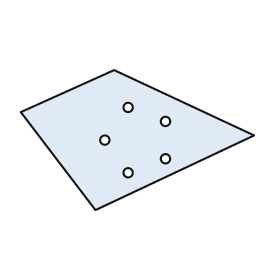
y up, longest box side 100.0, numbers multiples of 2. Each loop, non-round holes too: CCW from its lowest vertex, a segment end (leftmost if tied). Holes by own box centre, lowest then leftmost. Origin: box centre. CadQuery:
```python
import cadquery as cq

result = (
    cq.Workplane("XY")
    .moveTo(-18.0, -30.0)
    .lineTo(50.0, 2.0)
    .lineTo(-10.0, 30.0)
    .lineTo(-50.0, 12.0)
    .close()
    .moveTo(-4.0, -14.0)
    .circle(2.0)
    .moveTo(12.0, -8.0)
    .circle(2.0)
    .moveTo(-14.0, 0.0)
    .circle(2.0)
    .moveTo(12.0, 8.0)
    .circle(2.0)
    .moveTo(-4.0, 14.0)
    .circle(2.0)
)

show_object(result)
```